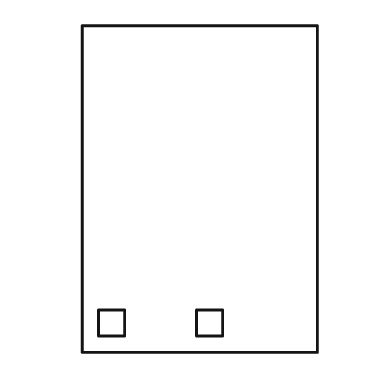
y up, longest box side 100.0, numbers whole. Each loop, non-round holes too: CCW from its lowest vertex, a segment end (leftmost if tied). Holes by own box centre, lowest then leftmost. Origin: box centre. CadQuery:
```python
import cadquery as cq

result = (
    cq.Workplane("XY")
    .moveTo(-36.0, -50.0)
    .lineTo(36.0, -50.0)
    .lineTo(36.0, 50.0)
    .lineTo(-36.0, 50.0)
    .close()
    .moveTo(-31.0, -45.0)
    .lineTo(-23.0, -45.0)
    .lineTo(-23.0, -37.0)
    .lineTo(-31.0, -37.0)
    .close()
    .moveTo(-1.0, -45.0)
    .lineTo(7.0, -45.0)
    .lineTo(7.0, -37.0)
    .lineTo(-1.0, -37.0)
    .close()
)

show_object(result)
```